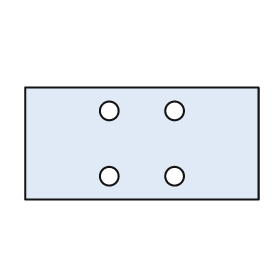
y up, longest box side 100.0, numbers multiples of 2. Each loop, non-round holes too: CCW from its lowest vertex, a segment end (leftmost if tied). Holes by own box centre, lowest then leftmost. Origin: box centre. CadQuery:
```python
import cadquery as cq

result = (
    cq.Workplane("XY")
    .moveTo(-50.0, -24.0)
    .lineTo(50.0, -24.0)
    .lineTo(50.0, 24.0)
    .lineTo(-50.0, 24.0)
    .close()
    .moveTo(-14.0, -14.0)
    .circle(4.0)
    .moveTo(14.0, -14.0)
    .circle(4.0)
    .moveTo(-14.0, 14.0)
    .circle(4.0)
    .moveTo(14.0, 14.0)
    .circle(4.0)
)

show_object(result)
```